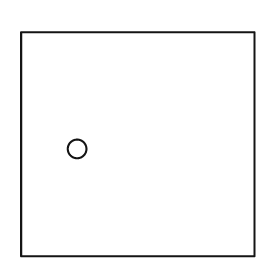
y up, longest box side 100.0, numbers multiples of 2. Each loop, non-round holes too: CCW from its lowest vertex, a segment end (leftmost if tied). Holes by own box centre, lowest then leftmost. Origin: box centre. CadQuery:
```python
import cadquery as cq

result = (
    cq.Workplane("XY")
    .moveTo(-50.0, -48.0)
    .lineTo(50.0, -48.0)
    .lineTo(50.0, 48.0)
    .lineTo(-50.0, 48.0)
    .close()
    .moveTo(-26.0, -2.0)
    .circle(4.0)
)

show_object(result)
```